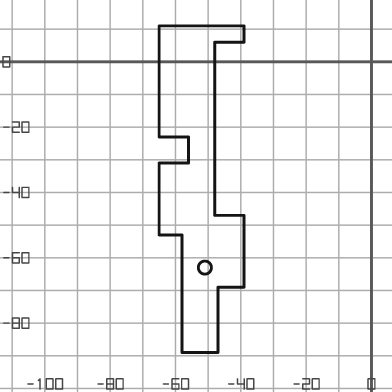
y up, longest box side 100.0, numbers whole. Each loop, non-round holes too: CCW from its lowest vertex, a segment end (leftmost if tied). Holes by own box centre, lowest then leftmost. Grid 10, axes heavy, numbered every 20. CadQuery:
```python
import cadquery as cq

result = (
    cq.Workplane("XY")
    .moveTo(-58.0, -89.0)
    .lineTo(-47.0, -89.0)
    .lineTo(-47.0, -69.0)
    .lineTo(-39.0, -69.0)
    .lineTo(-39.0, -47.0)
    .lineTo(-48.0, -47.0)
    .lineTo(-48.0, 6.0)
    .lineTo(-39.0, 6.0)
    .lineTo(-39.0, 11.0)
    .lineTo(-65.0, 11.0)
    .lineTo(-65.0, -23.0)
    .lineTo(-56.0, -23.0)
    .lineTo(-56.0, -31.0)
    .lineTo(-65.0, -31.0)
    .lineTo(-65.0, -53.0)
    .lineTo(-58.0, -53.0)
    .close()
    .moveTo(-51.0, -63.0)
    .circle(2.0)
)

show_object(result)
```